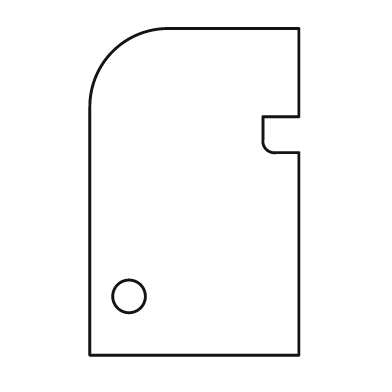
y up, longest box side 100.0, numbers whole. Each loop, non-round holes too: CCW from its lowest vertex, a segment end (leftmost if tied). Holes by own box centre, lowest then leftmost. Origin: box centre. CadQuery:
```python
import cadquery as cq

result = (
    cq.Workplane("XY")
    .moveTo(-32.0, -50.0)
    .lineTo(32.0, -50.0)
    .lineTo(32.0, 12.0)
    .lineTo(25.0, 12.0)
    .threePointArc((22.0, 13.0), (21.0, 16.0))
    .lineTo(21.0, 23.0)
    .lineTo(32.0, 23.0)
    .lineTo(32.0, 50.0)
    .lineTo(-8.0, 50.0)
    .threePointArc((-25.0, 43.0), (-32.0, 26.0))
    .close()
    .moveTo(-20.0, -32.0)
    .circle(5.0)
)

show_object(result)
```